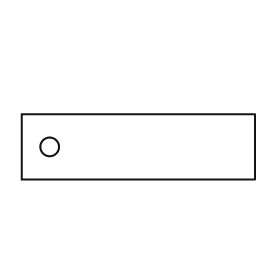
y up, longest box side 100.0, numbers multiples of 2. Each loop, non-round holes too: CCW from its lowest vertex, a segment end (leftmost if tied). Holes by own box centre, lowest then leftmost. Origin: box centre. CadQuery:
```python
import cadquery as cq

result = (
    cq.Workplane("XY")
    .moveTo(-50.0, -14.0)
    .lineTo(50.0, -14.0)
    .lineTo(50.0, 14.0)
    .lineTo(-50.0, 14.0)
    .close()
    .moveTo(-38.0, 0.0)
    .circle(4.0)
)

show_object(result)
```